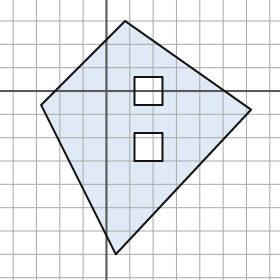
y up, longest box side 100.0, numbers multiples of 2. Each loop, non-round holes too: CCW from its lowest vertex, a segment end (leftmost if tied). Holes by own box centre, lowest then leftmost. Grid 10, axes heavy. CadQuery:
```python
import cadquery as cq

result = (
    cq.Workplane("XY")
    .moveTo(4.0, -70.0)
    .lineTo(62.0, -8.0)
    .lineTo(8.0, 30.0)
    .lineTo(-28.0, -6.0)
    .close()
    .moveTo(12.0, -30.0)
    .lineTo(24.0, -30.0)
    .lineTo(24.0, -18.0)
    .lineTo(12.0, -18.0)
    .close()
    .moveTo(12.0, -6.0)
    .lineTo(24.0, -6.0)
    .lineTo(24.0, 6.0)
    .lineTo(12.0, 6.0)
    .close()
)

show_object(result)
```